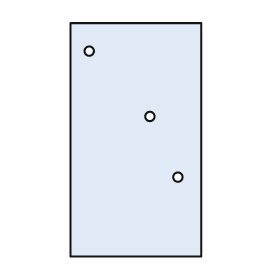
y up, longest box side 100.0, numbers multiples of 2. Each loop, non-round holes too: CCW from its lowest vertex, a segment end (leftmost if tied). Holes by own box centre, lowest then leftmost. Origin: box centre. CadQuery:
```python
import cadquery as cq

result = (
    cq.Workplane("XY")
    .moveTo(-28.0, -50.0)
    .lineTo(28.0, -50.0)
    .lineTo(28.0, 50.0)
    .lineTo(-28.0, 50.0)
    .close()
    .moveTo(18.0, -16.0)
    .circle(2.0)
    .moveTo(6.0, 10.0)
    .circle(2.0)
    .moveTo(-20.0, 38.0)
    .circle(2.0)
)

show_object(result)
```